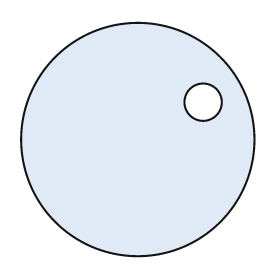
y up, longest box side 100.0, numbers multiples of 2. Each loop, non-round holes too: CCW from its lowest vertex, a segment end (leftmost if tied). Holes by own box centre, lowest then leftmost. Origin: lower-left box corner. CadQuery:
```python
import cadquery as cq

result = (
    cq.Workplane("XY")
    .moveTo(50.0, 50.0)
    .circle(50.0)
    .moveTo(78.0, 66.0)
    .circle(8.0)
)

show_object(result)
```